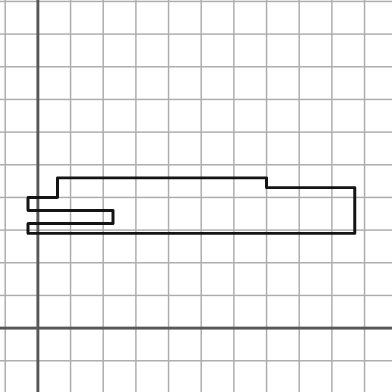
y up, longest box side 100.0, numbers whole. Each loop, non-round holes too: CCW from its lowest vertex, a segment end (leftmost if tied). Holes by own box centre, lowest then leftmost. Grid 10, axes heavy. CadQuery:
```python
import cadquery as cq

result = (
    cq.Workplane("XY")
    .moveTo(-3.0, 29.0)
    .lineTo(97.0, 29.0)
    .lineTo(97.0, 43.0)
    .lineTo(70.0, 43.0)
    .lineTo(70.0, 46.0)
    .lineTo(6.0, 46.0)
    .lineTo(6.0, 40.0)
    .lineTo(-3.0, 40.0)
    .lineTo(-3.0, 36.0)
    .lineTo(23.0, 36.0)
    .lineTo(23.0, 32.0)
    .lineTo(-3.0, 32.0)
    .close()
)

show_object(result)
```